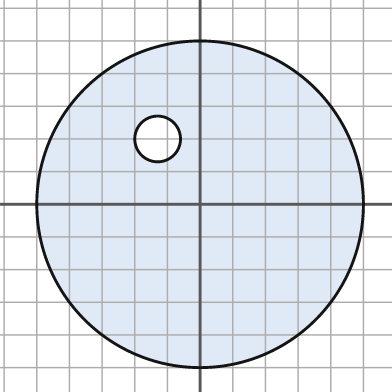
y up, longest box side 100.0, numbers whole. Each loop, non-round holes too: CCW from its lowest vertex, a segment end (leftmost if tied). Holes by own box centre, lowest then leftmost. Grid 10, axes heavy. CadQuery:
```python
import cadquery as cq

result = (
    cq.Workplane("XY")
    .moveTo(0.0, 0.0)
    .circle(50.0)
    .moveTo(-13.0, 20.0)
    .circle(7.0)
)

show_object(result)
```